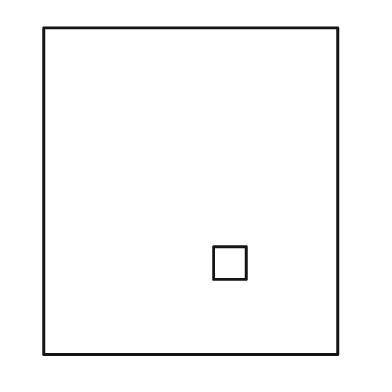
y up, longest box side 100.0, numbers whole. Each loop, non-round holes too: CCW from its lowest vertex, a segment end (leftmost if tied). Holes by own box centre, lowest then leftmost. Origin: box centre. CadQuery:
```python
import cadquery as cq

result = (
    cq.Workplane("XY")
    .moveTo(-45.0, -50.0)
    .lineTo(45.0, -50.0)
    .lineTo(45.0, 50.0)
    .lineTo(-45.0, 50.0)
    .close()
    .moveTo(7.0, -27.0)
    .lineTo(17.0, -27.0)
    .lineTo(17.0, -17.0)
    .lineTo(7.0, -17.0)
    .close()
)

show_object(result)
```